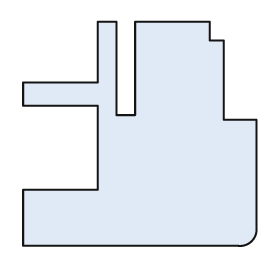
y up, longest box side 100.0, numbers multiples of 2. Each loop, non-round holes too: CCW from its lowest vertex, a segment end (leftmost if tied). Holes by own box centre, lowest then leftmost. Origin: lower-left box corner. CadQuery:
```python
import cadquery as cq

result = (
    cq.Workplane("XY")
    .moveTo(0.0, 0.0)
    .lineTo(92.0, 0.0)
    .threePointArc((98.0, 2.0), (100.0, 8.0))
    .lineTo(100.0, 54.0)
    .lineTo(86.0, 54.0)
    .lineTo(86.0, 88.0)
    .lineTo(80.0, 88.0)
    .lineTo(80.0, 96.0)
    .lineTo(48.0, 96.0)
    .lineTo(48.0, 56.0)
    .lineTo(40.0, 56.0)
    .lineTo(40.0, 96.0)
    .lineTo(32.0, 96.0)
    .lineTo(32.0, 70.0)
    .lineTo(0.0, 70.0)
    .lineTo(0.0, 60.0)
    .lineTo(32.0, 60.0)
    .lineTo(32.0, 24.0)
    .lineTo(0.0, 24.0)
    .close()
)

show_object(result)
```